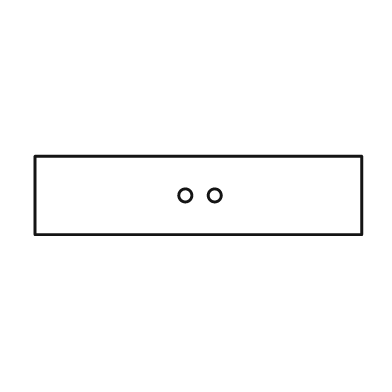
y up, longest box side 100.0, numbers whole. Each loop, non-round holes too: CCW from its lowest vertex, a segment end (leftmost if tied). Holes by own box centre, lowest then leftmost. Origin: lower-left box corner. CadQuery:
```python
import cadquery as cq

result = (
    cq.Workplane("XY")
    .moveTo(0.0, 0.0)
    .lineTo(100.0, 0.0)
    .lineTo(100.0, 24.0)
    .lineTo(0.0, 24.0)
    .close()
    .moveTo(46.0, 12.0)
    .circle(2.0)
    .moveTo(55.0, 12.0)
    .circle(2.0)
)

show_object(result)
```